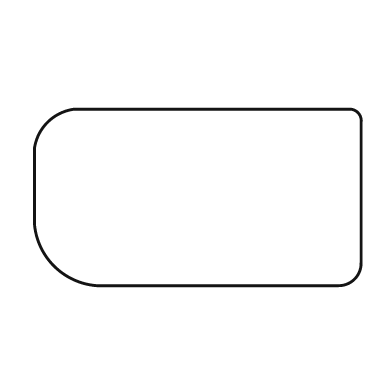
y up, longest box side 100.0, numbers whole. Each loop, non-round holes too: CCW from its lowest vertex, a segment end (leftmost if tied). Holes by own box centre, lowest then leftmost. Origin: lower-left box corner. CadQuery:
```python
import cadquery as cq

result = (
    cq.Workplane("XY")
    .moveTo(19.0, 0.0)
    .lineTo(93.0, 0.0)
    .threePointArc((98.0, 2.0), (100.0, 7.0))
    .lineTo(100.0, 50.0)
    .threePointArc((99.0, 53.0), (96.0, 54.0))
    .lineTo(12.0, 54.0)
    .threePointArc((4.0, 50.0), (0.0, 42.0))
    .lineTo(0.0, 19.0)
    .threePointArc((6.0, 6.0), (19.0, 0.0))
    .close()
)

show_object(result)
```